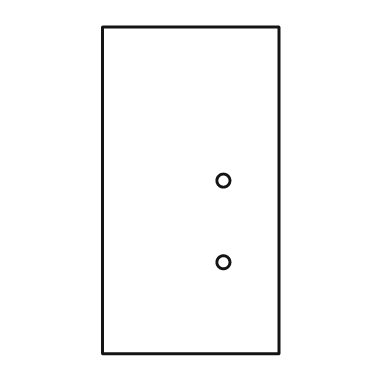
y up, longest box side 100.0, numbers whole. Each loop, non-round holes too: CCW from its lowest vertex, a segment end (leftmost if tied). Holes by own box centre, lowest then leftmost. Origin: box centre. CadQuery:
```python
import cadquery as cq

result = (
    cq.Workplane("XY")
    .moveTo(-27.0, -50.0)
    .lineTo(27.0, -50.0)
    .lineTo(27.0, 50.0)
    .lineTo(-27.0, 50.0)
    .close()
    .moveTo(10.0, -22.0)
    .circle(2.0)
    .moveTo(10.0, 3.0)
    .circle(2.0)
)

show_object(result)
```